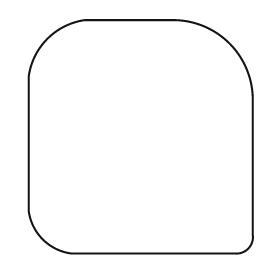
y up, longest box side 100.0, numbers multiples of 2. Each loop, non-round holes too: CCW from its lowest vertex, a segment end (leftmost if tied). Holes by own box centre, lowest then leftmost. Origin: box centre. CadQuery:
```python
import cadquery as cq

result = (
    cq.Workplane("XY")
    .moveTo(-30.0, -50.0)
    .lineTo(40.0, -50.0)
    .threePointArc((46.0, -48.0), (48.0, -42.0))
    .lineTo(48.0, 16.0)
    .threePointArc((38.0, 40.0), (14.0, 50.0))
    .lineTo(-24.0, 50.0)
    .threePointArc((-40.0, 42.0), (-48.0, 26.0))
    .lineTo(-48.0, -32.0)
    .threePointArc((-42.0, -44.0), (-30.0, -50.0))
    .close()
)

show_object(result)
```